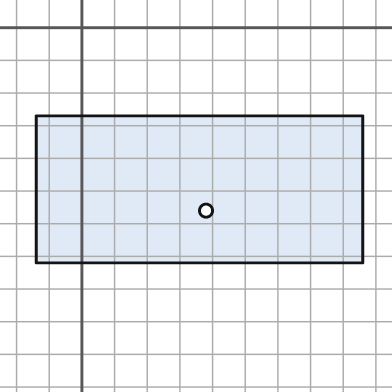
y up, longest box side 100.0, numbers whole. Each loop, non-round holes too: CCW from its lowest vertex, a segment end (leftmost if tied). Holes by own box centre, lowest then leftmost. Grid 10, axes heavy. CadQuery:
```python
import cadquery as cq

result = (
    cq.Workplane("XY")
    .moveTo(-14.0, -72.0)
    .lineTo(86.0, -72.0)
    .lineTo(86.0, -27.0)
    .lineTo(-14.0, -27.0)
    .close()
    .moveTo(38.0, -56.0)
    .circle(2.0)
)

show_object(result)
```